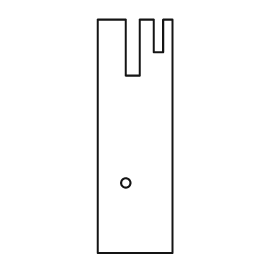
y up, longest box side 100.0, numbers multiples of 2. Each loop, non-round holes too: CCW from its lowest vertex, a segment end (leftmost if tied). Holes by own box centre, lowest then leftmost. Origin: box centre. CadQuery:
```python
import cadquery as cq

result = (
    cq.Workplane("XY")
    .moveTo(-16.0, -50.0)
    .lineTo(16.0, -50.0)
    .lineTo(16.0, 50.0)
    .lineTo(12.0, 50.0)
    .lineTo(12.0, 36.0)
    .lineTo(8.0, 36.0)
    .lineTo(8.0, 50.0)
    .lineTo(2.0, 50.0)
    .lineTo(2.0, 26.0)
    .lineTo(-4.0, 26.0)
    .lineTo(-4.0, 50.0)
    .lineTo(-16.0, 50.0)
    .close()
    .moveTo(-4.0, -20.0)
    .circle(2.0)
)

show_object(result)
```